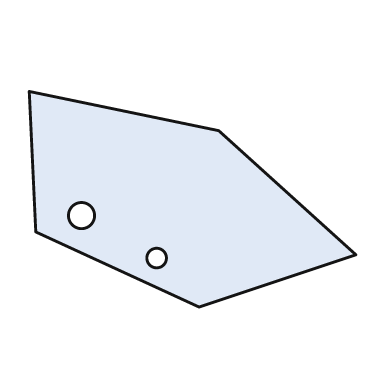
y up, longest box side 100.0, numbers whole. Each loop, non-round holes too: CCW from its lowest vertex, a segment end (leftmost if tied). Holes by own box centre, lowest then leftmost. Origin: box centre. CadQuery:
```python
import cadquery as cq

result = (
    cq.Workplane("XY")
    .moveTo(2.0, -33.0)
    .lineTo(50.0, -17.0)
    .lineTo(8.0, 21.0)
    .lineTo(-50.0, 33.0)
    .lineTo(-48.0, -10.0)
    .close()
    .moveTo(-11.0, -18.0)
    .circle(3.0)
    .moveTo(-34.0, -5.0)
    .circle(4.0)
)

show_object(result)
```